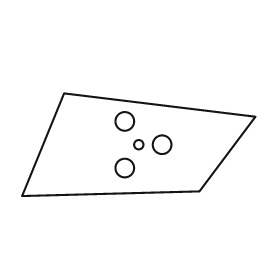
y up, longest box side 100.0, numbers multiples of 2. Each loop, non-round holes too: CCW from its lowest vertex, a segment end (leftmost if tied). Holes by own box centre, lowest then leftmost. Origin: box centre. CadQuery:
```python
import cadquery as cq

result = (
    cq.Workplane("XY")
    .moveTo(-50.0, -22.0)
    .lineTo(26.0, -20.0)
    .lineTo(50.0, 12.0)
    .lineTo(-32.0, 22.0)
    .close()
    .moveTo(-6.0, -10.0)
    .circle(4.0)
    .moveTo(0.0, 0.0)
    .circle(2.0)
    .moveTo(10.0, 0.0)
    .circle(4.0)
    .moveTo(-6.0, 10.0)
    .circle(4.0)
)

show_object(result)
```